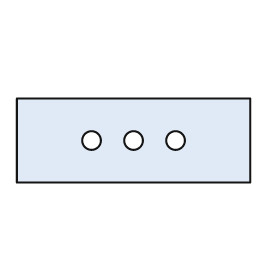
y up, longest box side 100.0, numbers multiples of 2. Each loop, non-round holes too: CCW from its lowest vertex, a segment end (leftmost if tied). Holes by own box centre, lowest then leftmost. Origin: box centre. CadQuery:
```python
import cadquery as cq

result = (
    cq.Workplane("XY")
    .moveTo(-50.0, -18.0)
    .lineTo(50.0, -18.0)
    .lineTo(50.0, 18.0)
    .lineTo(-50.0, 18.0)
    .close()
    .moveTo(-18.0, 0.0)
    .circle(4.0)
    .moveTo(0.0, 0.0)
    .circle(4.0)
    .moveTo(18.0, 0.0)
    .circle(4.0)
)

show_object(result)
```